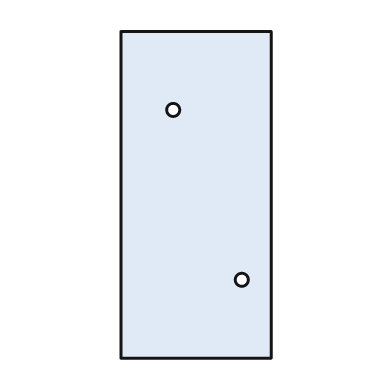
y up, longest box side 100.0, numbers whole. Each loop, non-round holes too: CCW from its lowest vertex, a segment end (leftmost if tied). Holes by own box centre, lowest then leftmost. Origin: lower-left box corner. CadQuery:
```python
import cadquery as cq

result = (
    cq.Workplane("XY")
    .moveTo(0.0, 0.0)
    .lineTo(46.0, 0.0)
    .lineTo(46.0, 100.0)
    .lineTo(0.0, 100.0)
    .close()
    .moveTo(37.0, 24.0)
    .circle(2.0)
    .moveTo(16.0, 76.0)
    .circle(2.0)
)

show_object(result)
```